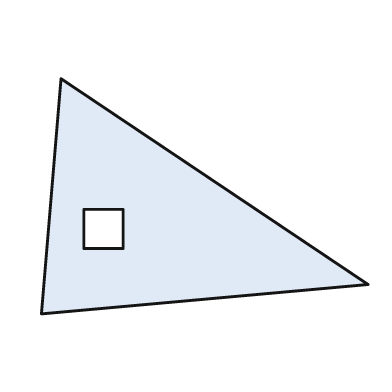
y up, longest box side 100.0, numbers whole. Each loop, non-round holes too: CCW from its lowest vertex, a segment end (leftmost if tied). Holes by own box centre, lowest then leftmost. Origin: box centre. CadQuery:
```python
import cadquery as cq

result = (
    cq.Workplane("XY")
    .moveTo(-50.0, -36.0)
    .lineTo(50.0, -27.0)
    .lineTo(-44.0, 36.0)
    .close()
    .moveTo(-37.0, -16.0)
    .lineTo(-25.0, -16.0)
    .lineTo(-25.0, -4.0)
    .lineTo(-37.0, -4.0)
    .close()
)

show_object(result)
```